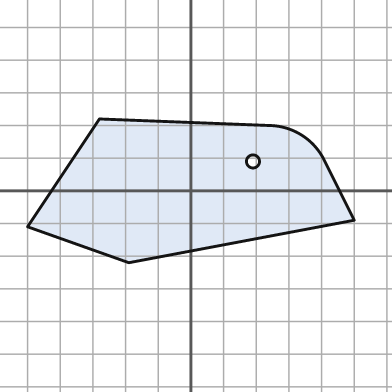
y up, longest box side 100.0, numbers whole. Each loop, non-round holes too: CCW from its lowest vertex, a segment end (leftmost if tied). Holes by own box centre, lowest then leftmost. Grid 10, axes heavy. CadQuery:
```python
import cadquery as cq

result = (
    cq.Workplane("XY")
    .moveTo(-19.0, -22.0)
    .lineTo(50.0, -9.0)
    .lineTo(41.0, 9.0)
    .threePointArc((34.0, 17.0), (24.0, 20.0))
    .lineTo(-28.0, 22.0)
    .lineTo(-50.0, -11.0)
    .close()
    .moveTo(19.0, 9.0)
    .circle(2.0)
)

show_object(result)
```